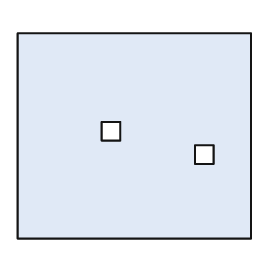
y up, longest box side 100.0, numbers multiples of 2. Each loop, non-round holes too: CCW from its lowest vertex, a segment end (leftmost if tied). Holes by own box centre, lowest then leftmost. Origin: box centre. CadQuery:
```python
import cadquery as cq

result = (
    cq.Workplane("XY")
    .moveTo(-50.0, -44.0)
    .lineTo(50.0, -44.0)
    .lineTo(50.0, 44.0)
    .lineTo(-50.0, 44.0)
    .close()
    .moveTo(26.0, -12.0)
    .lineTo(34.0, -12.0)
    .lineTo(34.0, -4.0)
    .lineTo(26.0, -4.0)
    .close()
    .moveTo(-14.0, -2.0)
    .lineTo(-6.0, -2.0)
    .lineTo(-6.0, 6.0)
    .lineTo(-14.0, 6.0)
    .close()
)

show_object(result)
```